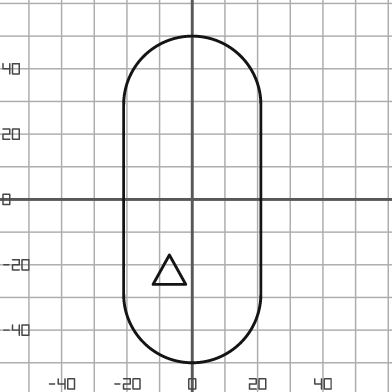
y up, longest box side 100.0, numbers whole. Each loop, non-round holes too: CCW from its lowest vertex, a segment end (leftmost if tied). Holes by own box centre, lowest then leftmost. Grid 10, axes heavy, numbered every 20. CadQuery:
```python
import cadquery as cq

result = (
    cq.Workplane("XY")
    .moveTo(-21.0, -29.0)
    .threePointArc((0.0, -50.0), (21.0, -29.0))
    .lineTo(21.0, 29.0)
    .threePointArc((0.0, 50.0), (-21.0, 29.0))
    .close()
    .moveTo(-12.0, -26.0)
    .lineTo(-2.0, -26.0)
    .lineTo(-7.0, -17.0)
    .close()
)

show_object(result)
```